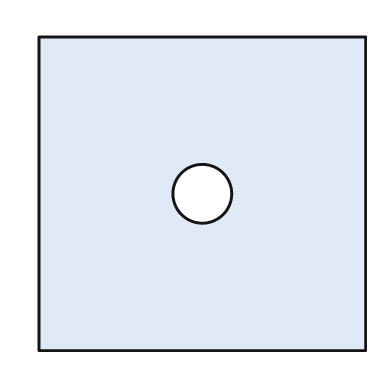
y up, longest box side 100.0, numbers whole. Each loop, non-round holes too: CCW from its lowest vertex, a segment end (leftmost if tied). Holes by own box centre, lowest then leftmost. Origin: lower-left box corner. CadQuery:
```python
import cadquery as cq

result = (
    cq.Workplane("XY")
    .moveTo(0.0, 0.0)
    .lineTo(100.0, 0.0)
    .lineTo(100.0, 96.0)
    .lineTo(0.0, 96.0)
    .close()
    .moveTo(50.0, 48.0)
    .circle(9.0)
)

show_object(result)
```